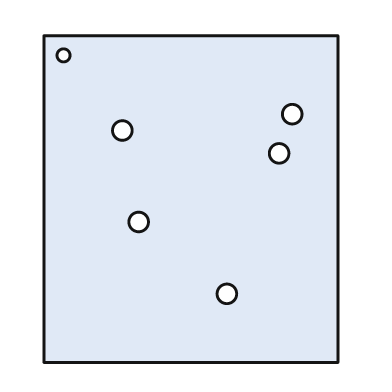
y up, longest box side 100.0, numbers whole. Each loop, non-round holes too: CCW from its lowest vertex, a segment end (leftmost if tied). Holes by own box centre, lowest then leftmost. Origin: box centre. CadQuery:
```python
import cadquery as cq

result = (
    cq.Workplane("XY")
    .moveTo(-45.0, -50.0)
    .lineTo(45.0, -50.0)
    .lineTo(45.0, 50.0)
    .lineTo(-45.0, 50.0)
    .close()
    .moveTo(11.0, -29.0)
    .circle(3.0)
    .moveTo(-16.0, -7.0)
    .circle(3.0)
    .moveTo(27.0, 14.0)
    .circle(3.0)
    .moveTo(-21.0, 21.0)
    .circle(3.0)
    .moveTo(31.0, 26.0)
    .circle(3.0)
    .moveTo(-39.0, 44.0)
    .circle(2.0)
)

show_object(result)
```